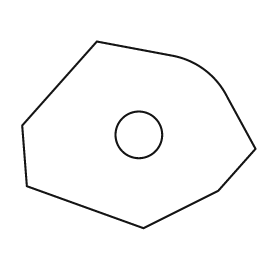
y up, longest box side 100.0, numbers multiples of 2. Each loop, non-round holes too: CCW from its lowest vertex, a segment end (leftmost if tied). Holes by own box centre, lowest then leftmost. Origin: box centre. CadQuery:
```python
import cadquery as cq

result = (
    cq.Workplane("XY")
    .moveTo(2.0, -40.0)
    .lineTo(34.0, -24.0)
    .lineTo(50.0, -6.0)
    .lineTo(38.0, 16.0)
    .threePointArc((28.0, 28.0), (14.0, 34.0))
    .lineTo(-18.0, 40.0)
    .lineTo(-50.0, 4.0)
    .lineTo(-48.0, -22.0)
    .close()
    .moveTo(0.0, 0.0)
    .circle(10.0)
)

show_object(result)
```